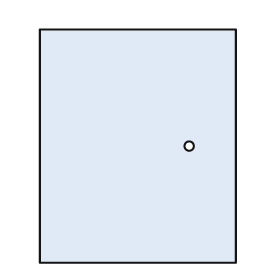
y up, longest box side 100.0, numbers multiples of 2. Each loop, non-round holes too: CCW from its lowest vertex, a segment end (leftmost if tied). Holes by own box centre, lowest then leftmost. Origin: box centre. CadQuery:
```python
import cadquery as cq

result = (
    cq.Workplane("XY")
    .moveTo(-42.0, -50.0)
    .lineTo(42.0, -50.0)
    .lineTo(42.0, 50.0)
    .lineTo(-42.0, 50.0)
    .close()
    .moveTo(22.0, 0.0)
    .circle(2.0)
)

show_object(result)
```